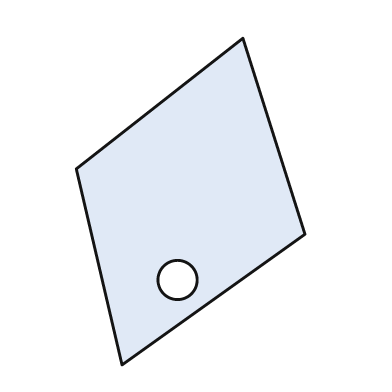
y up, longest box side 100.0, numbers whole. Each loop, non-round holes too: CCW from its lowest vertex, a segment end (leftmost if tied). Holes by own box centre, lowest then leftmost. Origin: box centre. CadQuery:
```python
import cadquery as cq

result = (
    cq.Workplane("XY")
    .moveTo(-21.0, -50.0)
    .lineTo(35.0, -10.0)
    .lineTo(16.0, 50.0)
    .lineTo(-35.0, 10.0)
    .close()
    .moveTo(-4.0, -24.0)
    .circle(6.0)
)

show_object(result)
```